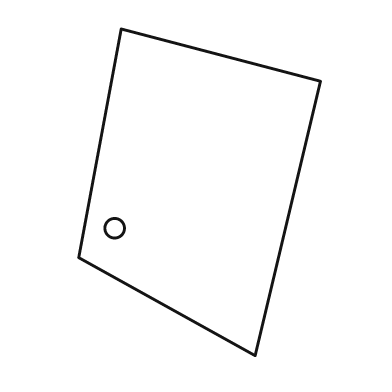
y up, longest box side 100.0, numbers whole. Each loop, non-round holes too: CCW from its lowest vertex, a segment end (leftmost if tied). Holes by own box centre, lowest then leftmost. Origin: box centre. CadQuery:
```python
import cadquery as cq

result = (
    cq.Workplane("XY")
    .moveTo(17.0, -50.0)
    .lineTo(37.0, 34.0)
    .lineTo(-24.0, 50.0)
    .lineTo(-37.0, -20.0)
    .close()
    .moveTo(-26.0, -11.0)
    .circle(3.0)
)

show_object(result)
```